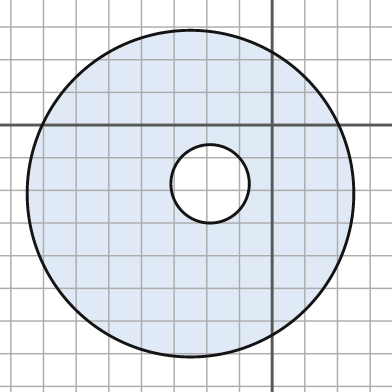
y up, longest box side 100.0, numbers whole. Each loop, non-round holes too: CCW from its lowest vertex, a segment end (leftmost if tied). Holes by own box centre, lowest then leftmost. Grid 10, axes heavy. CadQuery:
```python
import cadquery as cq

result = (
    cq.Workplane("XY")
    .moveTo(-25.0, -21.0)
    .circle(50.0)
    .moveTo(-19.0, -18.0)
    .circle(12.0)
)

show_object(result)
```